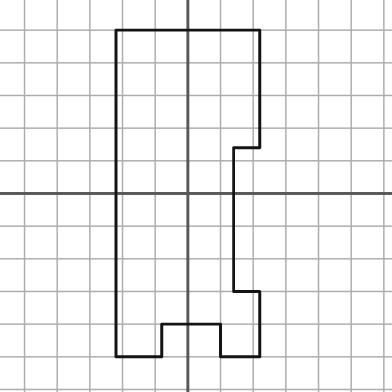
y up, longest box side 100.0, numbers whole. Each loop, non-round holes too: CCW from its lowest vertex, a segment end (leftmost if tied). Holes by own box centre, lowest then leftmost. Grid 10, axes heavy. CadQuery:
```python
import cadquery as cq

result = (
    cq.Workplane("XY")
    .moveTo(-22.0, -50.0)
    .lineTo(-8.0, -50.0)
    .lineTo(-8.0, -40.0)
    .lineTo(10.0, -40.0)
    .lineTo(10.0, -50.0)
    .lineTo(22.0, -50.0)
    .lineTo(22.0, -30.0)
    .lineTo(14.0, -30.0)
    .lineTo(14.0, 14.0)
    .lineTo(22.0, 14.0)
    .lineTo(22.0, 50.0)
    .lineTo(-22.0, 50.0)
    .close()
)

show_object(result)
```